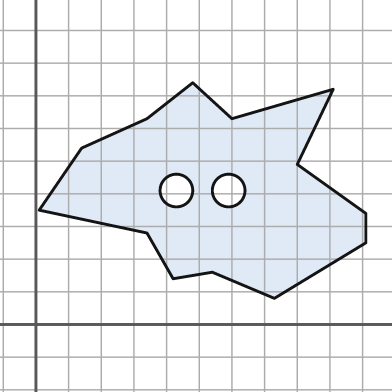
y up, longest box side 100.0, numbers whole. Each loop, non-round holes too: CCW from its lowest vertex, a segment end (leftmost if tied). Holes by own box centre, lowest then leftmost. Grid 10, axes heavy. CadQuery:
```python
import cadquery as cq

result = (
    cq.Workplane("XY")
    .moveTo(73.0, 8.0)
    .lineTo(101.0, 25.0)
    .lineTo(101.0, 34.0)
    .lineTo(80.0, 49.0)
    .lineTo(91.0, 72.0)
    .lineTo(60.0, 63.0)
    .lineTo(48.0, 74.0)
    .lineTo(34.0, 63.0)
    .lineTo(14.0, 54.0)
    .lineTo(1.0, 35.0)
    .lineTo(34.0, 28.0)
    .lineTo(42.0, 14.0)
    .lineTo(54.0, 16.0)
    .close()
    .moveTo(43.0, 41.0)
    .circle(5.0)
    .moveTo(59.0, 41.0)
    .circle(5.0)
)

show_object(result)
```